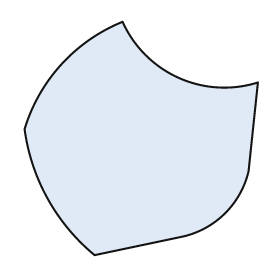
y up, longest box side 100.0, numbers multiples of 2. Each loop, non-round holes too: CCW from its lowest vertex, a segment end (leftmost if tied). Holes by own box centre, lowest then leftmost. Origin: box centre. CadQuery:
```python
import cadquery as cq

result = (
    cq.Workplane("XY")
    .moveTo(-20.0, -50.0)
    .lineTo(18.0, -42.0)
    .threePointArc((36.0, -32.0), (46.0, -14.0))
    .lineTo(50.0, 24.0)
    .threePointArc((16.0, 26.0), (-8.0, 50.0))
    .threePointArc((-34.0, 32.0), (-50.0, 4.0))
    .threePointArc((-40.0, -26.0), (-20.0, -50.0))
    .close()
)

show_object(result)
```